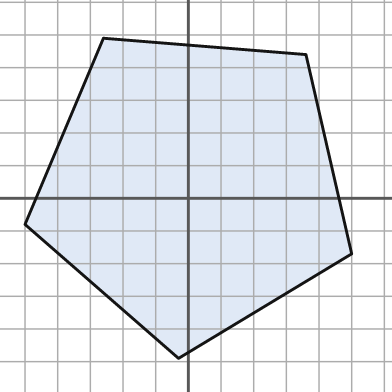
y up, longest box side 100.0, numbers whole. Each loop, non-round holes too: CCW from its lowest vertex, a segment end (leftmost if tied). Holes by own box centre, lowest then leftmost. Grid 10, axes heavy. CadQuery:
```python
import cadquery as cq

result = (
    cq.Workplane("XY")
    .moveTo(-3.0, -49.0)
    .lineTo(50.0, -17.0)
    .lineTo(36.0, 44.0)
    .lineTo(-26.0, 49.0)
    .lineTo(-50.0, -8.0)
    .close()
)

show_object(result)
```